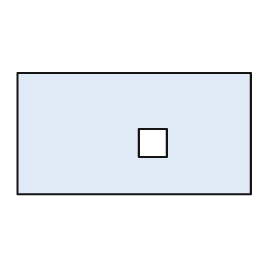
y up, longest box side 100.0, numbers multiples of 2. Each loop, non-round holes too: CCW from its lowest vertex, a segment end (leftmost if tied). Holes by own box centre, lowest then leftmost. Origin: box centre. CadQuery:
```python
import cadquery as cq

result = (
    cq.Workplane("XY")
    .moveTo(-50.0, -26.0)
    .lineTo(50.0, -26.0)
    .lineTo(50.0, 26.0)
    .lineTo(-50.0, 26.0)
    .close()
    .moveTo(2.0, -10.0)
    .lineTo(14.0, -10.0)
    .lineTo(14.0, 2.0)
    .lineTo(2.0, 2.0)
    .close()
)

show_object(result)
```